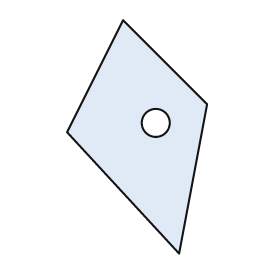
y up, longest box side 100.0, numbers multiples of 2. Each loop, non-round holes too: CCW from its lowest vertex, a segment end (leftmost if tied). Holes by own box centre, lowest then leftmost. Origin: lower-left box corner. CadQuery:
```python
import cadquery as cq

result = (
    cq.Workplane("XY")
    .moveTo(48.0, 0.0)
    .lineTo(60.0, 64.0)
    .lineTo(24.0, 100.0)
    .lineTo(0.0, 52.0)
    .close()
    .moveTo(38.0, 56.0)
    .circle(6.0)
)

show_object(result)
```